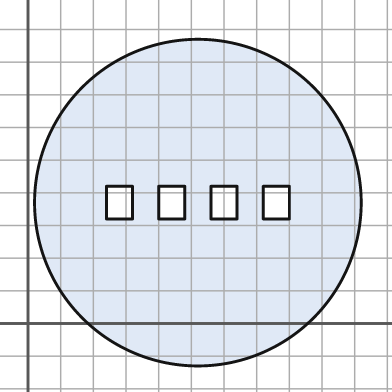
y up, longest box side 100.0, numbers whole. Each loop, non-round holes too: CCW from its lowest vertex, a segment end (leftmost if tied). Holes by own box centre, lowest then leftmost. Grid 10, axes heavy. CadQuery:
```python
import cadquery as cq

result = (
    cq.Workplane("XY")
    .moveTo(52.0, 37.0)
    .circle(50.0)
    .moveTo(24.0, 32.0)
    .lineTo(32.0, 32.0)
    .lineTo(32.0, 42.0)
    .lineTo(24.0, 42.0)
    .close()
    .moveTo(40.0, 32.0)
    .lineTo(48.0, 32.0)
    .lineTo(48.0, 42.0)
    .lineTo(40.0, 42.0)
    .close()
    .moveTo(56.0, 32.0)
    .lineTo(64.0, 32.0)
    .lineTo(64.0, 42.0)
    .lineTo(56.0, 42.0)
    .close()
    .moveTo(72.0, 32.0)
    .lineTo(80.0, 32.0)
    .lineTo(80.0, 42.0)
    .lineTo(72.0, 42.0)
    .close()
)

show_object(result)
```